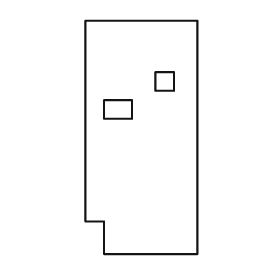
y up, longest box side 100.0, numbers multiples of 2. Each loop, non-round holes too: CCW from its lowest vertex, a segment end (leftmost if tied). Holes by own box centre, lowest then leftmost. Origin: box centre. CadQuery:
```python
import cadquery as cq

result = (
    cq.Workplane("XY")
    .moveTo(-16.0, -50.0)
    .lineTo(24.0, -50.0)
    .lineTo(24.0, 50.0)
    .lineTo(-24.0, 50.0)
    .lineTo(-24.0, -36.0)
    .lineTo(-16.0, -36.0)
    .close()
    .moveTo(-16.0, 8.0)
    .lineTo(-4.0, 8.0)
    .lineTo(-4.0, 16.0)
    .lineTo(-16.0, 16.0)
    .close()
    .moveTo(6.0, 20.0)
    .lineTo(14.0, 20.0)
    .lineTo(14.0, 28.0)
    .lineTo(6.0, 28.0)
    .close()
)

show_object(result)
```